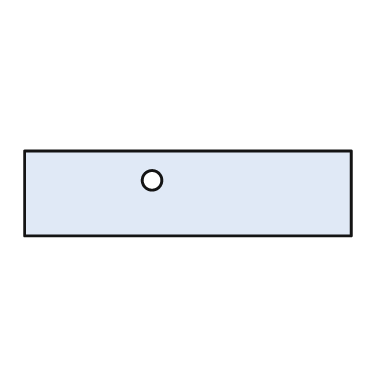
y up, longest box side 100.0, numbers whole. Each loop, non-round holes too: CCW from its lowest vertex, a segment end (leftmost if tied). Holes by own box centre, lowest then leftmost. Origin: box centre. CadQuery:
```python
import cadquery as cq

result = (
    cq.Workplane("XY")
    .moveTo(-50.0, -13.0)
    .lineTo(50.0, -13.0)
    .lineTo(50.0, 13.0)
    .lineTo(-50.0, 13.0)
    .close()
    .moveTo(-11.0, 4.0)
    .circle(3.0)
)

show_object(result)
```